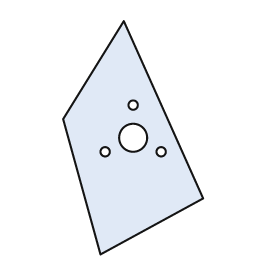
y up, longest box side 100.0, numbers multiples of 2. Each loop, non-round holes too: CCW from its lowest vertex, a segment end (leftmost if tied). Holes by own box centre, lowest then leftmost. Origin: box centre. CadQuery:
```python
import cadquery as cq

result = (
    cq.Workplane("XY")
    .moveTo(-14.0, -50.0)
    .lineTo(30.0, -26.0)
    .lineTo(-4.0, 50.0)
    .lineTo(-30.0, 8.0)
    .close()
    .moveTo(-12.0, -6.0)
    .circle(2.0)
    .moveTo(12.0, -6.0)
    .circle(2.0)
    .moveTo(0.0, 0.0)
    .circle(6.0)
    .moveTo(0.0, 14.0)
    .circle(2.0)
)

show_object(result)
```